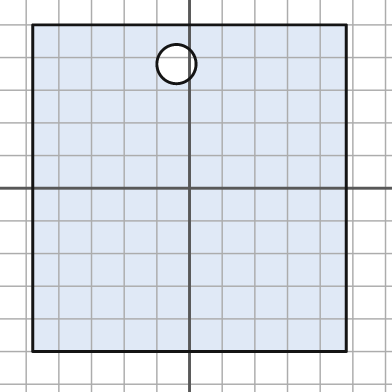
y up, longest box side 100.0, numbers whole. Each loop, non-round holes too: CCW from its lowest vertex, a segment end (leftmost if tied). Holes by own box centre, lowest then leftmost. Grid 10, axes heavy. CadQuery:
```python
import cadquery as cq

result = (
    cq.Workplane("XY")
    .moveTo(-48.0, -50.0)
    .lineTo(48.0, -50.0)
    .lineTo(48.0, 50.0)
    .lineTo(-48.0, 50.0)
    .close()
    .moveTo(-4.0, 38.0)
    .circle(6.0)
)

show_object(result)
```